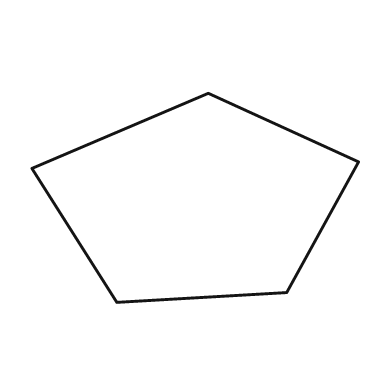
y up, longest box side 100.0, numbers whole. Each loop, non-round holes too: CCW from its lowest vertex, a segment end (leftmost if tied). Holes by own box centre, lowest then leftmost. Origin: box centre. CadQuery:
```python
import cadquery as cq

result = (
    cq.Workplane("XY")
    .moveTo(-24.0, -32.0)
    .lineTo(28.0, -29.0)
    .lineTo(50.0, 11.0)
    .lineTo(4.0, 32.0)
    .lineTo(-50.0, 9.0)
    .close()
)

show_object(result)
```